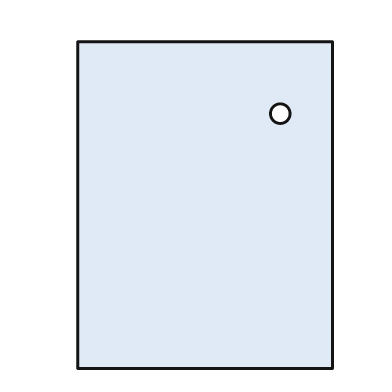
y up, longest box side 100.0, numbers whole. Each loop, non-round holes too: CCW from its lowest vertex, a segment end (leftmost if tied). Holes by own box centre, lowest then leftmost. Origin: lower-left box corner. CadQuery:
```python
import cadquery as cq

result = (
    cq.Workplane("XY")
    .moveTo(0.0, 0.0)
    .lineTo(78.0, 0.0)
    .lineTo(78.0, 100.0)
    .lineTo(0.0, 100.0)
    .close()
    .moveTo(62.0, 78.0)
    .circle(3.0)
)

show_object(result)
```